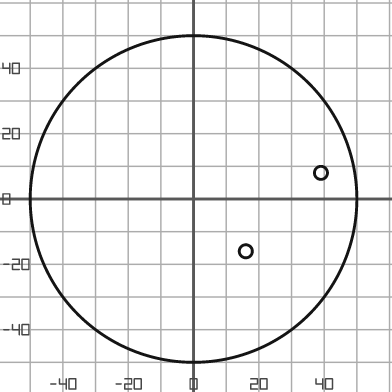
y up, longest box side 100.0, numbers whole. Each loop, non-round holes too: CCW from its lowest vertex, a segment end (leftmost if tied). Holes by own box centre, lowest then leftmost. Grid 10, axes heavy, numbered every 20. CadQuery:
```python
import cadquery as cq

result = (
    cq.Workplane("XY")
    .moveTo(0.0, 0.0)
    .circle(50.0)
    .moveTo(16.0, -16.0)
    .circle(2.0)
    .moveTo(39.0, 8.0)
    .circle(2.0)
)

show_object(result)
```